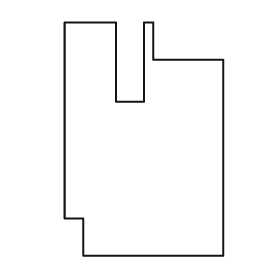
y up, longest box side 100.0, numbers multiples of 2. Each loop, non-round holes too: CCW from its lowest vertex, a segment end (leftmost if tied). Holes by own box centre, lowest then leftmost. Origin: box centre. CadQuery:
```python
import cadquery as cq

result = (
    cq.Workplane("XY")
    .moveTo(-26.0, -50.0)
    .lineTo(34.0, -50.0)
    .lineTo(34.0, 34.0)
    .lineTo(4.0, 34.0)
    .lineTo(4.0, 50.0)
    .lineTo(0.0, 50.0)
    .lineTo(0.0, 16.0)
    .lineTo(-12.0, 16.0)
    .lineTo(-12.0, 50.0)
    .lineTo(-34.0, 50.0)
    .lineTo(-34.0, -34.0)
    .lineTo(-26.0, -34.0)
    .close()
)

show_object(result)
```